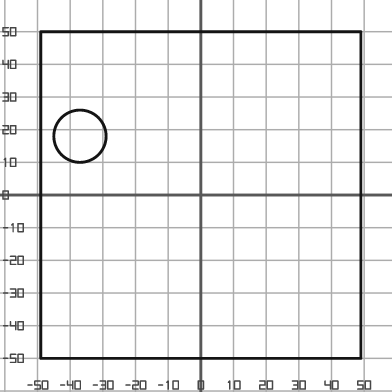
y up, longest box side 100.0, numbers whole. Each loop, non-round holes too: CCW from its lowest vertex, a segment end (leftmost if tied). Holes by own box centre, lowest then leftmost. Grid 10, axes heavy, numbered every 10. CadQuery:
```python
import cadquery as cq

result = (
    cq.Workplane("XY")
    .moveTo(-49.0, -50.0)
    .lineTo(49.0, -50.0)
    .lineTo(49.0, 50.0)
    .lineTo(-49.0, 50.0)
    .close()
    .moveTo(-37.0, 18.0)
    .circle(8.0)
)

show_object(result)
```